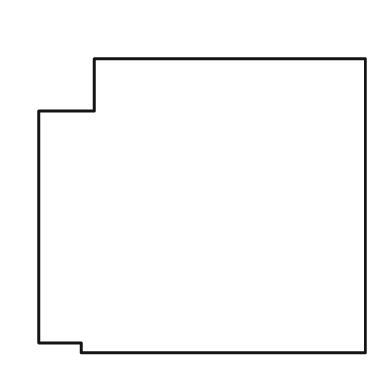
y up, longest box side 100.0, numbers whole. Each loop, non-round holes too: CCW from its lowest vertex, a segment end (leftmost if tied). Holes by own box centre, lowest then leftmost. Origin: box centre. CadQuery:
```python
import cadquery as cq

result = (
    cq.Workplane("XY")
    .moveTo(-37.0, -45.0)
    .lineTo(50.0, -45.0)
    .lineTo(50.0, 45.0)
    .lineTo(-33.0, 45.0)
    .lineTo(-33.0, 29.0)
    .lineTo(-50.0, 29.0)
    .lineTo(-50.0, -42.0)
    .lineTo(-37.0, -42.0)
    .close()
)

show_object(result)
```